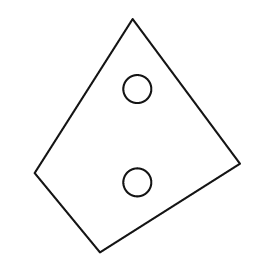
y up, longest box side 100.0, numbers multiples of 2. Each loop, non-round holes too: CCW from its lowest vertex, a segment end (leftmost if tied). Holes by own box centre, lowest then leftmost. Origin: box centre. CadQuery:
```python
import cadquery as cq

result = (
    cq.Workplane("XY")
    .moveTo(-16.0, -50.0)
    .lineTo(44.0, -12.0)
    .lineTo(-2.0, 50.0)
    .lineTo(-44.0, -16.0)
    .close()
    .moveTo(0.0, -20.0)
    .circle(6.0)
    .moveTo(0.0, 20.0)
    .circle(6.0)
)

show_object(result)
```